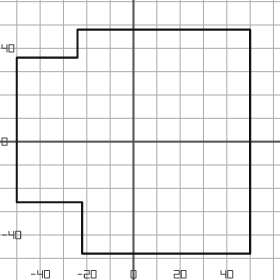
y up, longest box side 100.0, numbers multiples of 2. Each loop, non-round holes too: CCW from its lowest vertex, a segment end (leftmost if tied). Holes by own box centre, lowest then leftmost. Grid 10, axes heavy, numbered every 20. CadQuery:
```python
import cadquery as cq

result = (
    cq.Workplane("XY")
    .moveTo(-22.0, -48.0)
    .lineTo(50.0, -48.0)
    .lineTo(50.0, 48.0)
    .lineTo(-24.0, 48.0)
    .lineTo(-24.0, 36.0)
    .lineTo(-50.0, 36.0)
    .lineTo(-50.0, -26.0)
    .lineTo(-22.0, -26.0)
    .close()
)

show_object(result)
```